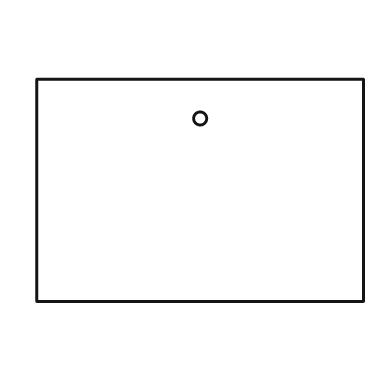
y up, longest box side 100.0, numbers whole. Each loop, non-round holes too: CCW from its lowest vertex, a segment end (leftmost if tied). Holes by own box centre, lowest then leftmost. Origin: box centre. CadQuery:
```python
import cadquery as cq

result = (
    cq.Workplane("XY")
    .moveTo(-50.0, -34.0)
    .lineTo(50.0, -34.0)
    .lineTo(50.0, 34.0)
    .lineTo(-50.0, 34.0)
    .close()
    .moveTo(0.0, 22.0)
    .circle(2.0)
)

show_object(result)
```